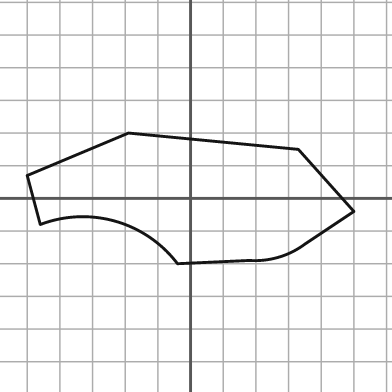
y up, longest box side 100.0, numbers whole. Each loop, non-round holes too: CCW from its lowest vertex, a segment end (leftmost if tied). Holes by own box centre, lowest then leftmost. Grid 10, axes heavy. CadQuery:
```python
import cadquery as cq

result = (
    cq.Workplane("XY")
    .moveTo(-4.0, -20.0)
    .lineTo(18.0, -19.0)
    .threePointArc((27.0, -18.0), (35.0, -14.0))
    .lineTo(50.0, -4.0)
    .lineTo(33.0, 15.0)
    .lineTo(-19.0, 20.0)
    .lineTo(-50.0, 7.0)
    .lineTo(-46.0, -8.0)
    .threePointArc((-23.0, -7.0), (-4.0, -20.0))
    .close()
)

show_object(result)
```